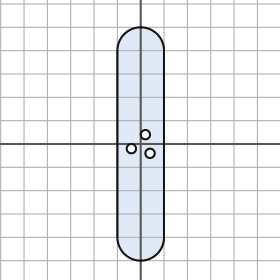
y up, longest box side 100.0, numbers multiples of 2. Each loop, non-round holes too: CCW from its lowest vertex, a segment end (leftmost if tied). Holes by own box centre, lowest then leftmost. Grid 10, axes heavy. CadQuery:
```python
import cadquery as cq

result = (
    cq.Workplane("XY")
    .moveTo(-10.0, -40.0)
    .threePointArc((0.0, -50.0), (10.0, -40.0))
    .lineTo(10.0, 40.0)
    .threePointArc((0.0, 50.0), (-10.0, 40.0))
    .close()
    .moveTo(4.0, -4.0)
    .circle(2.0)
    .moveTo(-4.0, -2.0)
    .circle(2.0)
    .moveTo(2.0, 4.0)
    .circle(2.0)
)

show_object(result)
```